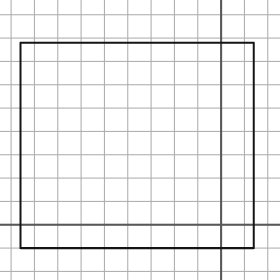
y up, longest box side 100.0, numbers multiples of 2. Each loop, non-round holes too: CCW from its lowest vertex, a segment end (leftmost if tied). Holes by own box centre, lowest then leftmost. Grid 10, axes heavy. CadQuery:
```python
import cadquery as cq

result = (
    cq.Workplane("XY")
    .moveTo(-86.0, -10.0)
    .lineTo(14.0, -10.0)
    .lineTo(14.0, 78.0)
    .lineTo(-86.0, 78.0)
    .close()
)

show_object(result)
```